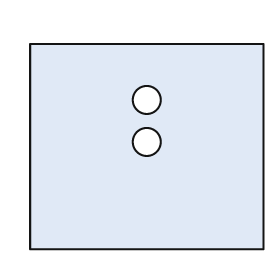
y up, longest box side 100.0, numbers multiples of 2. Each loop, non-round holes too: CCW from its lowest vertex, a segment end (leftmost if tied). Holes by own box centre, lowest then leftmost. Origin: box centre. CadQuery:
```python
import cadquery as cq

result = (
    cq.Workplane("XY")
    .moveTo(-50.0, -44.0)
    .lineTo(50.0, -44.0)
    .lineTo(50.0, 44.0)
    .lineTo(-50.0, 44.0)
    .close()
    .moveTo(0.0, 2.0)
    .circle(6.0)
    .moveTo(0.0, 20.0)
    .circle(6.0)
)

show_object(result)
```